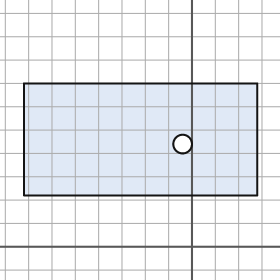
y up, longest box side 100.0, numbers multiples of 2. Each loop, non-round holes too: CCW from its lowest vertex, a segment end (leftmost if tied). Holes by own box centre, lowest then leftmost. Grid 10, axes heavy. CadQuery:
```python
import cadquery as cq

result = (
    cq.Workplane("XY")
    .moveTo(-72.0, 22.0)
    .lineTo(28.0, 22.0)
    .lineTo(28.0, 70.0)
    .lineTo(-72.0, 70.0)
    .close()
    .moveTo(-4.0, 44.0)
    .circle(4.0)
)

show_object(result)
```